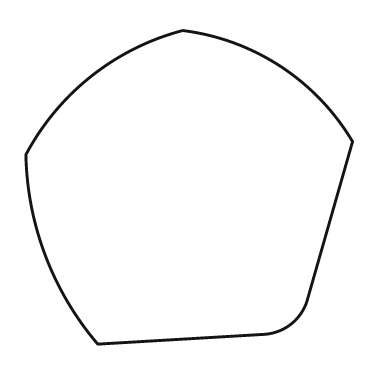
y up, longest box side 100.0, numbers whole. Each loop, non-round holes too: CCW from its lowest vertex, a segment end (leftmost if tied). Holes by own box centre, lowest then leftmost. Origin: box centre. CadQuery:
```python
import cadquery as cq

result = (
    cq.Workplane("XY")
    .moveTo(-28.0, -48.0)
    .lineTo(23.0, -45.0)
    .threePointArc((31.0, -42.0), (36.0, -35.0))
    .lineTo(50.0, 14.0)
    .threePointArc((28.0, 37.0), (-2.0, 48.0))
    .threePointArc((-30.0, 34.0), (-50.0, 10.0))
    .threePointArc((-44.0, -21.0), (-28.0, -48.0))
    .close()
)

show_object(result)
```